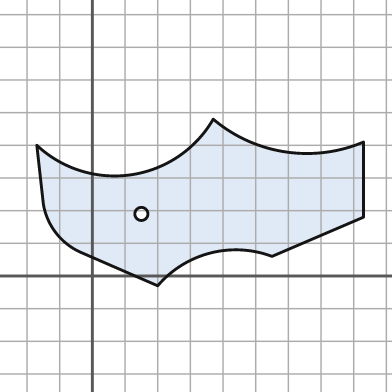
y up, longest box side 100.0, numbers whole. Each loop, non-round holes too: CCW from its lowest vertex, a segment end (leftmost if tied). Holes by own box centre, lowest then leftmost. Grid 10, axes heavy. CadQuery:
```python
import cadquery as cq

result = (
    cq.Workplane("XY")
    .moveTo(20.0, -3.0)
    .threePointArc((36.0, 7.0), (55.0, 6.0))
    .lineTo(83.0, 18.0)
    .lineTo(83.0, 41.0)
    .threePointArc((59.0, 38.0), (37.0, 48.0))
    .threePointArc((12.0, 31.0), (-17.0, 40.0))
    .lineTo(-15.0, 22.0)
    .threePointArc((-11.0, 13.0), (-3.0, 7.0))
    .close()
    .moveTo(15.0, 19.0)
    .circle(2.0)
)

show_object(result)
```